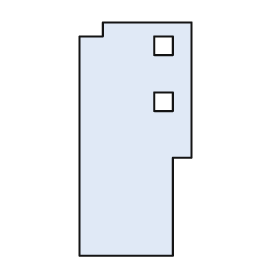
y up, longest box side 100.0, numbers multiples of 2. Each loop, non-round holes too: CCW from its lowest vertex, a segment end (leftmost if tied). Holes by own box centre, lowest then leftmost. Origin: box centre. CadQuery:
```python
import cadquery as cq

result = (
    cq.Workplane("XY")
    .moveTo(-24.0, -50.0)
    .lineTo(16.0, -50.0)
    .lineTo(16.0, -8.0)
    .lineTo(24.0, -8.0)
    .lineTo(24.0, 50.0)
    .lineTo(-14.0, 50.0)
    .lineTo(-14.0, 44.0)
    .lineTo(-24.0, 44.0)
    .close()
    .moveTo(8.0, 12.0)
    .lineTo(16.0, 12.0)
    .lineTo(16.0, 20.0)
    .lineTo(8.0, 20.0)
    .close()
    .moveTo(8.0, 36.0)
    .lineTo(16.0, 36.0)
    .lineTo(16.0, 44.0)
    .lineTo(8.0, 44.0)
    .close()
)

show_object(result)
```